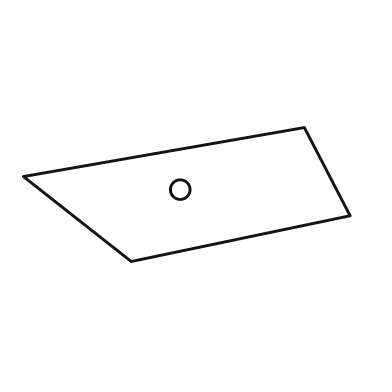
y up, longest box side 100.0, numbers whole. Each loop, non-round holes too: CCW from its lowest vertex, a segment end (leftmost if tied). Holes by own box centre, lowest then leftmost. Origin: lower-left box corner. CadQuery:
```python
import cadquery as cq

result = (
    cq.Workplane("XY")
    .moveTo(33.0, 0.0)
    .lineTo(100.0, 14.0)
    .lineTo(86.0, 41.0)
    .lineTo(0.0, 26.0)
    .close()
    .moveTo(48.0, 22.0)
    .circle(3.0)
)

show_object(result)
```